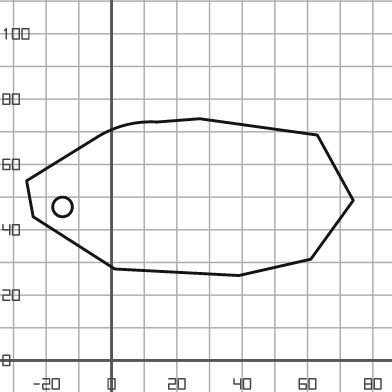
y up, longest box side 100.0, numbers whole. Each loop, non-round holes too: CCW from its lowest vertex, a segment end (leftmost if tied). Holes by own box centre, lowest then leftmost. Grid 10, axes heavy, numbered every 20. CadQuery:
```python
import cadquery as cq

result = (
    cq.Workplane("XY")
    .moveTo(39.0, 26.0)
    .lineTo(61.0, 31.0)
    .lineTo(74.0, 49.0)
    .lineTo(63.0, 69.0)
    .lineTo(27.0, 74.0)
    .lineTo(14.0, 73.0)
    .threePointArc((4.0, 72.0), (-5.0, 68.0))
    .lineTo(-26.0, 55.0)
    .lineTo(-24.0, 44.0)
    .lineTo(1.0, 28.0)
    .close()
    .moveTo(-15.0, 47.0)
    .circle(3.0)
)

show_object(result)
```